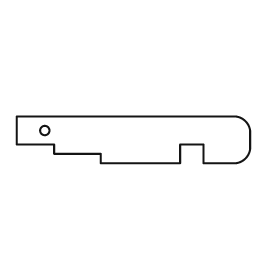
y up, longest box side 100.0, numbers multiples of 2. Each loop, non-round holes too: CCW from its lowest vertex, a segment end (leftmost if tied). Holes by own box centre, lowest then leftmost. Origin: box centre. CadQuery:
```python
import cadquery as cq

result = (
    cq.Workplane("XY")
    .moveTo(-14.0, -10.0)
    .lineTo(20.0, -10.0)
    .lineTo(20.0, -2.0)
    .lineTo(30.0, -2.0)
    .lineTo(30.0, -10.0)
    .lineTo(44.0, -10.0)
    .threePointArc((48.0, -8.0), (50.0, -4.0))
    .lineTo(50.0, 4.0)
    .threePointArc((48.0, 8.0), (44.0, 10.0))
    .lineTo(-50.0, 10.0)
    .lineTo(-50.0, -2.0)
    .lineTo(-34.0, -2.0)
    .lineTo(-34.0, -6.0)
    .lineTo(-14.0, -6.0)
    .close()
    .moveTo(-38.0, 4.0)
    .circle(2.0)
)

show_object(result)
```